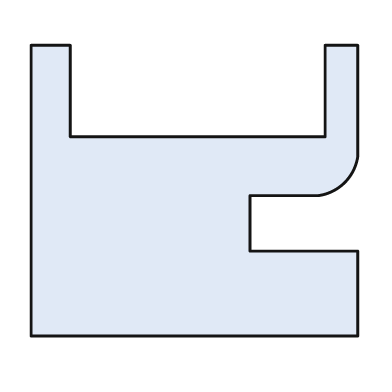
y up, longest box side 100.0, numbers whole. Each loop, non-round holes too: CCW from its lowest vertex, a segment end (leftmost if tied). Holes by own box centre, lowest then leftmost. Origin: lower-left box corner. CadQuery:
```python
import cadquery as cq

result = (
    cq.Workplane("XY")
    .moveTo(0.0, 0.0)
    .lineTo(100.0, 0.0)
    .lineTo(100.0, 26.0)
    .lineTo(67.0, 26.0)
    .lineTo(67.0, 43.0)
    .lineTo(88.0, 43.0)
    .threePointArc((96.0, 47.0), (100.0, 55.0))
    .lineTo(100.0, 89.0)
    .lineTo(90.0, 89.0)
    .lineTo(90.0, 61.0)
    .lineTo(12.0, 61.0)
    .lineTo(12.0, 89.0)
    .lineTo(0.0, 89.0)
    .close()
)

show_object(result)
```